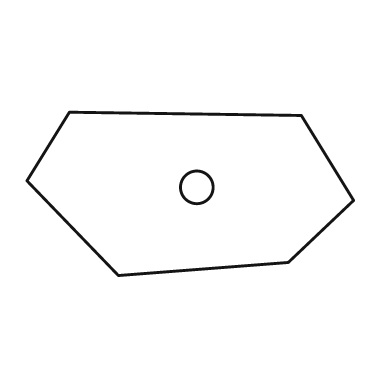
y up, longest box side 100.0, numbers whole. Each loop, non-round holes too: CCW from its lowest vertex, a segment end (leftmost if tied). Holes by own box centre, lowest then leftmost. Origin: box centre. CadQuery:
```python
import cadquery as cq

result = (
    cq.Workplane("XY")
    .moveTo(-22.0, -25.0)
    .lineTo(30.0, -21.0)
    .lineTo(50.0, -2.0)
    .lineTo(34.0, 24.0)
    .lineTo(-37.0, 25.0)
    .lineTo(-50.0, 4.0)
    .close()
    .moveTo(2.0, 2.0)
    .circle(5.0)
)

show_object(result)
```